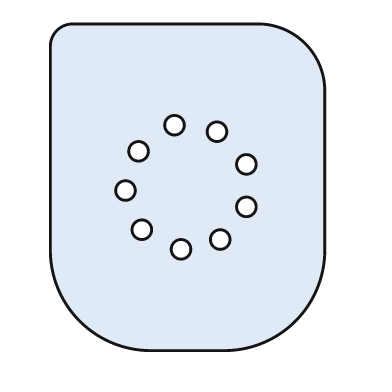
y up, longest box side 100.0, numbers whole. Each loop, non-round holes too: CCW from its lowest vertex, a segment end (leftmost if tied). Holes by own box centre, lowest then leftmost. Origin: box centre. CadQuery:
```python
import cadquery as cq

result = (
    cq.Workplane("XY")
    .moveTo(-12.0, -50.0)
    .lineTo(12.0, -50.0)
    .threePointArc((33.0, -41.0), (42.0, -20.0))
    .lineTo(42.0, 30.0)
    .threePointArc((36.0, 44.0), (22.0, 50.0))
    .lineTo(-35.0, 50.0)
    .threePointArc((-40.0, 48.0), (-42.0, 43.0))
    .lineTo(-42.0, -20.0)
    .threePointArc((-33.0, -41.0), (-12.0, -50.0))
    .close()
    .moveTo(-2.0, -19.0)
    .circle(3.0)
    .moveTo(10.0, -16.0)
    .circle(3.0)
    .moveTo(-14.0, -13.0)
    .circle(3.0)
    .moveTo(18.0, -6.0)
    .circle(3.0)
    .moveTo(-19.0, -1.0)
    .circle(3.0)
    .moveTo(18.0, 7.0)
    .circle(3.0)
    .moveTo(-15.0, 11.0)
    .circle(3.0)
    .moveTo(9.0, 17.0)
    .circle(3.0)
    .moveTo(-4.0, 19.0)
    .circle(3.0)
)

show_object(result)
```